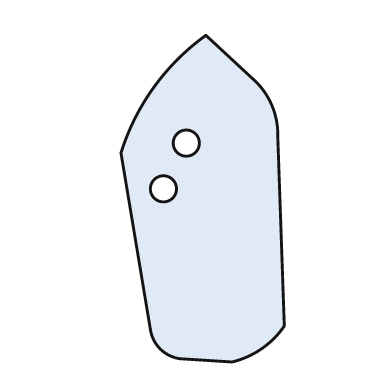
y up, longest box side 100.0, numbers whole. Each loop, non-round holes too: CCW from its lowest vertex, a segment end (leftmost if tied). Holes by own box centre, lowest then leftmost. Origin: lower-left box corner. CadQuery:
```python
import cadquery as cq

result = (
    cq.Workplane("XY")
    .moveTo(34.0, 0.0)
    .threePointArc((43.0, 4.0), (50.0, 11.0))
    .lineTo(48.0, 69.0)
    .threePointArc((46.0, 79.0), (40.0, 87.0))
    .lineTo(26.0, 100.0)
    .threePointArc((10.0, 84.0), (0.0, 64.0))
    .lineTo(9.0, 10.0)
    .threePointArc((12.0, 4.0), (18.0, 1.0))
    .close()
    .moveTo(13.0, 53.0)
    .circle(4.0)
    .moveTo(20.0, 67.0)
    .circle(4.0)
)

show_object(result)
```